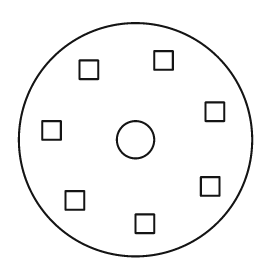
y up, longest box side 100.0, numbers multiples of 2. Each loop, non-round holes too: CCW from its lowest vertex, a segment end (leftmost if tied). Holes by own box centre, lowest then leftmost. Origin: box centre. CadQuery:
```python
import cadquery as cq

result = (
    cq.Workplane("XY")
    .moveTo(0.0, 0.0)
    .circle(50.0)
    .moveTo(0.0, -40.0)
    .lineTo(8.0, -40.0)
    .lineTo(8.0, -32.0)
    .lineTo(0.0, -32.0)
    .close()
    .moveTo(-30.0, -30.0)
    .lineTo(-22.0, -30.0)
    .lineTo(-22.0, -22.0)
    .lineTo(-30.0, -22.0)
    .close()
    .moveTo(28.0, -24.0)
    .lineTo(36.0, -24.0)
    .lineTo(36.0, -16.0)
    .lineTo(28.0, -16.0)
    .close()
    .moveTo(0.0, 0.0)
    .circle(8.0)
    .moveTo(-40.0, 0.0)
    .lineTo(-32.0, 0.0)
    .lineTo(-32.0, 8.0)
    .lineTo(-40.0, 8.0)
    .close()
    .moveTo(30.0, 8.0)
    .lineTo(38.0, 8.0)
    .lineTo(38.0, 16.0)
    .lineTo(30.0, 16.0)
    .close()
    .moveTo(-24.0, 26.0)
    .lineTo(-16.0, 26.0)
    .lineTo(-16.0, 34.0)
    .lineTo(-24.0, 34.0)
    .close()
    .moveTo(8.0, 30.0)
    .lineTo(16.0, 30.0)
    .lineTo(16.0, 38.0)
    .lineTo(8.0, 38.0)
    .close()
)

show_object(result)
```